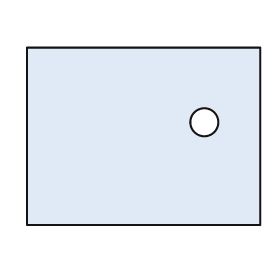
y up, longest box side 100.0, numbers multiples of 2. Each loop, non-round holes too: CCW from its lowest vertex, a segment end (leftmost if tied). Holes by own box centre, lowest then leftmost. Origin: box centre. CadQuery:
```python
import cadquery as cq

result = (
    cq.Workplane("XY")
    .moveTo(-50.0, -38.0)
    .lineTo(50.0, -38.0)
    .lineTo(50.0, 38.0)
    .lineTo(-50.0, 38.0)
    .close()
    .moveTo(26.0, 6.0)
    .circle(6.0)
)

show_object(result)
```